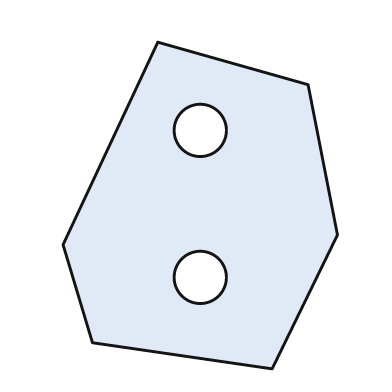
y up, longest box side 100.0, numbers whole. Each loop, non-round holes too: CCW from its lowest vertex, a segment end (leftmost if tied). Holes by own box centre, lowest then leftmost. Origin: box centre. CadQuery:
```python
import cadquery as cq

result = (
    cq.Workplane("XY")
    .moveTo(22.0, -50.0)
    .lineTo(42.0, -9.0)
    .lineTo(33.0, 37.0)
    .lineTo(-13.0, 50.0)
    .lineTo(-42.0, -12.0)
    .lineTo(-33.0, -42.0)
    .close()
    .moveTo(0.0, -22.0)
    .circle(8.0)
    .moveTo(0.0, 23.0)
    .circle(8.0)
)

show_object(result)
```